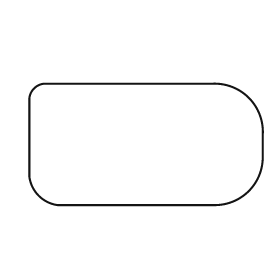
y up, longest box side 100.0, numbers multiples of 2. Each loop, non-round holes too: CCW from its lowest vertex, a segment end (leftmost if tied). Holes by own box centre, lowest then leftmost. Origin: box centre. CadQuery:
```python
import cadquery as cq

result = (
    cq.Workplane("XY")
    .moveTo(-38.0, -26.0)
    .lineTo(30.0, -26.0)
    .threePointArc((44.0, -20.0), (50.0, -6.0))
    .lineTo(50.0, 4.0)
    .threePointArc((44.0, 20.0), (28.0, 26.0))
    .lineTo(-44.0, 26.0)
    .threePointArc((-48.0, 24.0), (-50.0, 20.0))
    .lineTo(-50.0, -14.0)
    .threePointArc((-46.0, -22.0), (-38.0, -26.0))
    .close()
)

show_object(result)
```